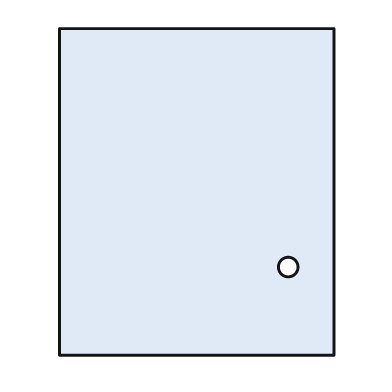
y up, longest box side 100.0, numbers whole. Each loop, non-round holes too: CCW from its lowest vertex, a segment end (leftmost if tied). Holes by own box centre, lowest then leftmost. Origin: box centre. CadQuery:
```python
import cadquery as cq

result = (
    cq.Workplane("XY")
    .moveTo(-42.0, -50.0)
    .lineTo(42.0, -50.0)
    .lineTo(42.0, 50.0)
    .lineTo(-42.0, 50.0)
    .close()
    .moveTo(28.0, -23.0)
    .circle(3.0)
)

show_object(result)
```